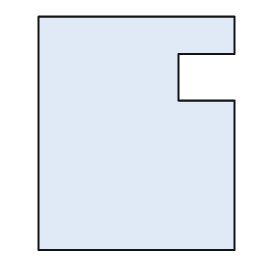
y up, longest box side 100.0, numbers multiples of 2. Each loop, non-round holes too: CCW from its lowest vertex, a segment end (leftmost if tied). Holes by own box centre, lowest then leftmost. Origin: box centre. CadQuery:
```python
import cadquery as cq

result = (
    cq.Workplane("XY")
    .moveTo(-42.0, -50.0)
    .lineTo(42.0, -50.0)
    .lineTo(42.0, 14.0)
    .lineTo(18.0, 14.0)
    .lineTo(18.0, 34.0)
    .lineTo(42.0, 34.0)
    .lineTo(42.0, 50.0)
    .lineTo(-42.0, 50.0)
    .close()
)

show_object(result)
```